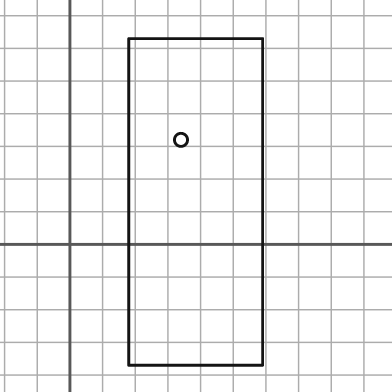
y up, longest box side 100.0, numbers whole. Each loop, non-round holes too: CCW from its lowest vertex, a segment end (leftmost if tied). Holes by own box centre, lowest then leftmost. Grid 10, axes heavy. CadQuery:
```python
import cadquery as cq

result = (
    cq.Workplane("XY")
    .moveTo(18.0, -37.0)
    .lineTo(59.0, -37.0)
    .lineTo(59.0, 63.0)
    .lineTo(18.0, 63.0)
    .close()
    .moveTo(34.0, 32.0)
    .circle(2.0)
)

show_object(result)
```